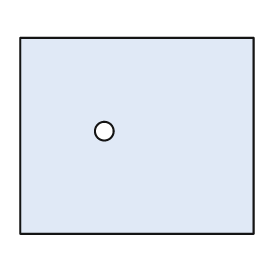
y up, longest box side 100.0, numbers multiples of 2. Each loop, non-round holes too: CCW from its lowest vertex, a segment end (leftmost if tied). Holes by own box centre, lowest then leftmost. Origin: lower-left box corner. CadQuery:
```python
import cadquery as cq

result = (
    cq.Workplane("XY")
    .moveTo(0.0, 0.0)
    .lineTo(100.0, 0.0)
    .lineTo(100.0, 84.0)
    .lineTo(0.0, 84.0)
    .close()
    .moveTo(36.0, 44.0)
    .circle(4.0)
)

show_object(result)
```